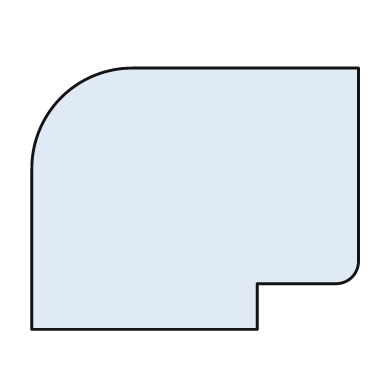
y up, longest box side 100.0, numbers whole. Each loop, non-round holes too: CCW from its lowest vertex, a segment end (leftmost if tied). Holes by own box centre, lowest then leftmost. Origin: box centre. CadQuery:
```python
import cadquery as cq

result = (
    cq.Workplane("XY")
    .moveTo(-50.0, -40.0)
    .lineTo(19.0, -40.0)
    .lineTo(19.0, -26.0)
    .lineTo(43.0, -26.0)
    .threePointArc((48.0, -24.0), (50.0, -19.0))
    .lineTo(50.0, 40.0)
    .lineTo(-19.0, 40.0)
    .threePointArc((-41.0, 31.0), (-50.0, 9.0))
    .close()
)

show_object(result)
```